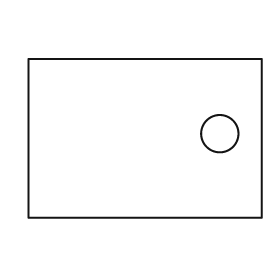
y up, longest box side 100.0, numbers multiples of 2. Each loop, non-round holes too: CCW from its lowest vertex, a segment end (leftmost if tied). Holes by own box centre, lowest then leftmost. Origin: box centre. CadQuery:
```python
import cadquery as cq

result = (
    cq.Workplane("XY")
    .moveTo(-50.0, -34.0)
    .lineTo(50.0, -34.0)
    .lineTo(50.0, 34.0)
    .lineTo(-50.0, 34.0)
    .close()
    .moveTo(32.0, 2.0)
    .circle(8.0)
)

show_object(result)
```